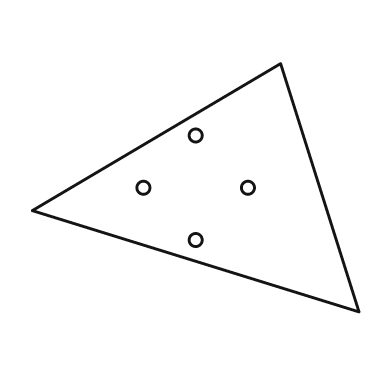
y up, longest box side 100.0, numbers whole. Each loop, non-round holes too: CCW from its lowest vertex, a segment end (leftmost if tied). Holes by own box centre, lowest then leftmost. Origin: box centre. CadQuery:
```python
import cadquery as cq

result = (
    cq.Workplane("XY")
    .moveTo(50.0, -38.0)
    .lineTo(26.0, 38.0)
    .lineTo(-50.0, -7.0)
    .close()
    .moveTo(0.0, -16.0)
    .circle(2.0)
    .moveTo(-16.0, 0.0)
    .circle(2.0)
    .moveTo(16.0, 0.0)
    .circle(2.0)
    .moveTo(0.0, 16.0)
    .circle(2.0)
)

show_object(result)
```